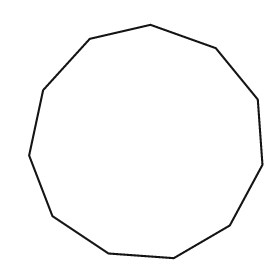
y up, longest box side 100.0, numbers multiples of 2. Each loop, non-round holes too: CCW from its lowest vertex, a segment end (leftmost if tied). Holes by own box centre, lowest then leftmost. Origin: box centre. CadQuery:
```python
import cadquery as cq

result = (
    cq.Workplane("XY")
    .moveTo(12.0, -50.0)
    .lineTo(36.0, -36.0)
    .lineTo(50.0, -10.0)
    .lineTo(48.0, 18.0)
    .lineTo(30.0, 40.0)
    .lineTo(2.0, 50.0)
    .lineTo(-24.0, 44.0)
    .lineTo(-44.0, 22.0)
    .lineTo(-50.0, -6.0)
    .lineTo(-40.0, -32.0)
    .lineTo(-16.0, -48.0)
    .close()
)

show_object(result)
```